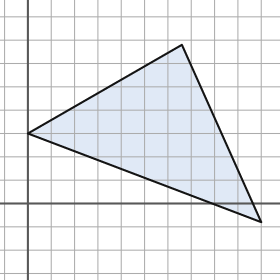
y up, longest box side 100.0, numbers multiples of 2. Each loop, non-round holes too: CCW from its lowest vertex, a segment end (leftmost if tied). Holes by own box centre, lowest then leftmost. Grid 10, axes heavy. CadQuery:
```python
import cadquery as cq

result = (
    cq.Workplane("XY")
    .moveTo(100.0, -8.0)
    .lineTo(66.0, 68.0)
    .lineTo(0.0, 30.0)
    .close()
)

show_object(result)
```